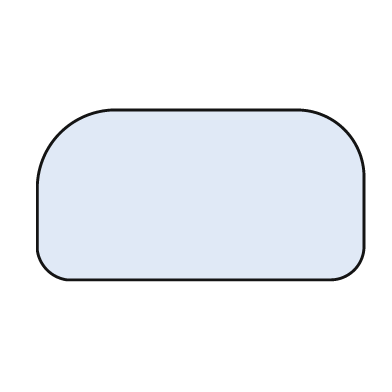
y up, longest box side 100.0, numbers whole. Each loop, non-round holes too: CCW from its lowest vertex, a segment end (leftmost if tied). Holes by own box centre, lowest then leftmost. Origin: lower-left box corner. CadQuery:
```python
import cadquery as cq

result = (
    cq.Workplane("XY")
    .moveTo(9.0, 0.0)
    .lineTo(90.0, 0.0)
    .threePointArc((97.0, 3.0), (100.0, 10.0))
    .lineTo(100.0, 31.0)
    .threePointArc((94.0, 46.0), (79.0, 52.0))
    .lineTo(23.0, 52.0)
    .threePointArc((7.0, 45.0), (0.0, 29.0))
    .lineTo(0.0, 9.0)
    .threePointArc((3.0, 3.0), (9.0, 0.0))
    .close()
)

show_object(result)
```